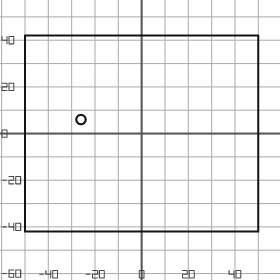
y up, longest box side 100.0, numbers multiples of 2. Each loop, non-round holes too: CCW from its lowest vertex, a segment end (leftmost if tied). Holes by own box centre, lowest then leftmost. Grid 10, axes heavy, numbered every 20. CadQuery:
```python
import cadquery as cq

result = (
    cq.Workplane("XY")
    .moveTo(-50.0, -42.0)
    .lineTo(50.0, -42.0)
    .lineTo(50.0, 42.0)
    .lineTo(-50.0, 42.0)
    .close()
    .moveTo(-26.0, 6.0)
    .circle(2.0)
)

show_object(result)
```